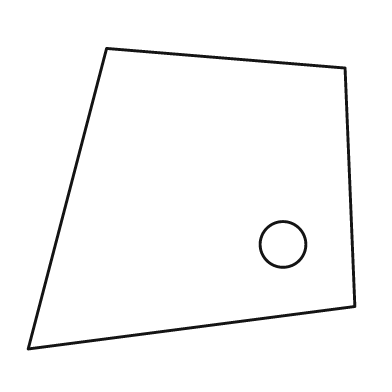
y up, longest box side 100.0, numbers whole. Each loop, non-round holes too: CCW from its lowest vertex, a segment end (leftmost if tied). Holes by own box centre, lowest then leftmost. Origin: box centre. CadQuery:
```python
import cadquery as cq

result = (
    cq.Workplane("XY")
    .moveTo(-50.0, -46.0)
    .lineTo(50.0, -33.0)
    .lineTo(47.0, 40.0)
    .lineTo(-26.0, 46.0)
    .close()
    .moveTo(28.0, -14.0)
    .circle(7.0)
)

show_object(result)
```